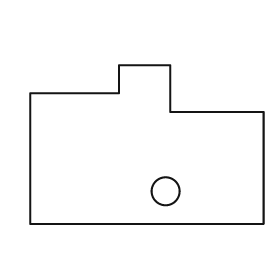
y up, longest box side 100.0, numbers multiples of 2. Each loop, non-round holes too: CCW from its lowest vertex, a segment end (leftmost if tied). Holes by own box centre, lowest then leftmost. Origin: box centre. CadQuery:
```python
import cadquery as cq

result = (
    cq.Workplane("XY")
    .moveTo(-50.0, -34.0)
    .lineTo(50.0, -34.0)
    .lineTo(50.0, 14.0)
    .lineTo(10.0, 14.0)
    .lineTo(10.0, 34.0)
    .lineTo(-12.0, 34.0)
    .lineTo(-12.0, 22.0)
    .lineTo(-50.0, 22.0)
    .close()
    .moveTo(8.0, -20.0)
    .circle(6.0)
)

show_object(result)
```